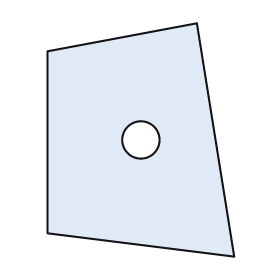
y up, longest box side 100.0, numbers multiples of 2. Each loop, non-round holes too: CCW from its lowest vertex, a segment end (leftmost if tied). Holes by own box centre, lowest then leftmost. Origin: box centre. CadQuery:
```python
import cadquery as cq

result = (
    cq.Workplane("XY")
    .moveTo(40.0, -50.0)
    .lineTo(24.0, 50.0)
    .lineTo(-40.0, 38.0)
    .lineTo(-40.0, -40.0)
    .close()
    .moveTo(0.0, 0.0)
    .circle(8.0)
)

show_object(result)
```